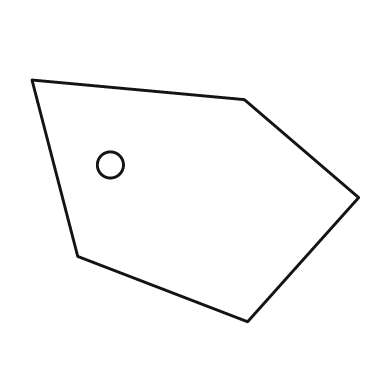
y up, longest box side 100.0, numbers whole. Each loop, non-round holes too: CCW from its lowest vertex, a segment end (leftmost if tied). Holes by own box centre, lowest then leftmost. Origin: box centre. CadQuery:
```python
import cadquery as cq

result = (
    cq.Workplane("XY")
    .moveTo(16.0, -37.0)
    .lineTo(50.0, 1.0)
    .lineTo(15.0, 31.0)
    .lineTo(-50.0, 37.0)
    .lineTo(-36.0, -17.0)
    .close()
    .moveTo(-26.0, 11.0)
    .circle(4.0)
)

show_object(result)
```